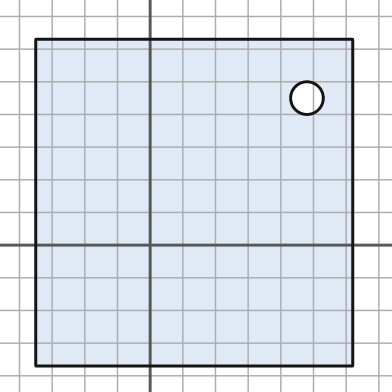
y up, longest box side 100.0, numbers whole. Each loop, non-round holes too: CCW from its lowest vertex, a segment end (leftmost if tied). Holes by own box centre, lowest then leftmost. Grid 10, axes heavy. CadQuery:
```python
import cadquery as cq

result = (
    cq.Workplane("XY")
    .moveTo(-35.0, -37.0)
    .lineTo(62.0, -37.0)
    .lineTo(62.0, 63.0)
    .lineTo(-35.0, 63.0)
    .close()
    .moveTo(48.0, 45.0)
    .circle(5.0)
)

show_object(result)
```